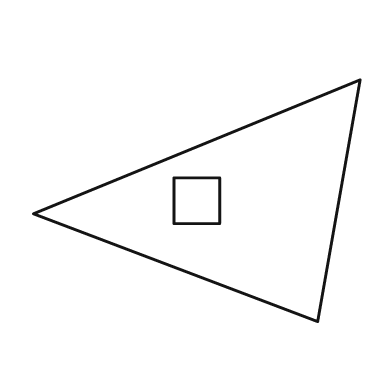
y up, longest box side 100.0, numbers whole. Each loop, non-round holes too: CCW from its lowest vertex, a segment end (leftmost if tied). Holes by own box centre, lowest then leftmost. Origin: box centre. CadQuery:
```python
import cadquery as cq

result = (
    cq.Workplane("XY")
    .moveTo(37.0, -37.0)
    .lineTo(50.0, 37.0)
    .lineTo(-50.0, -4.0)
    .close()
    .moveTo(-7.0, -7.0)
    .lineTo(7.0, -7.0)
    .lineTo(7.0, 7.0)
    .lineTo(-7.0, 7.0)
    .close()
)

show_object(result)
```